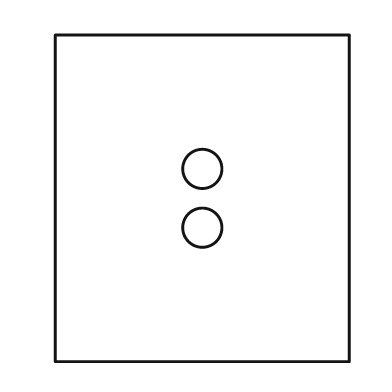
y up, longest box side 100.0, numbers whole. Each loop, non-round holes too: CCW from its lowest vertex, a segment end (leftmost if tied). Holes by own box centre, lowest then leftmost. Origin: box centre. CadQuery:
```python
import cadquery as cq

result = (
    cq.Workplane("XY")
    .moveTo(-45.0, -50.0)
    .lineTo(45.0, -50.0)
    .lineTo(45.0, 50.0)
    .lineTo(-45.0, 50.0)
    .close()
    .moveTo(0.0, -9.0)
    .circle(6.0)
    .moveTo(0.0, 9.0)
    .circle(6.0)
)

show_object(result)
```